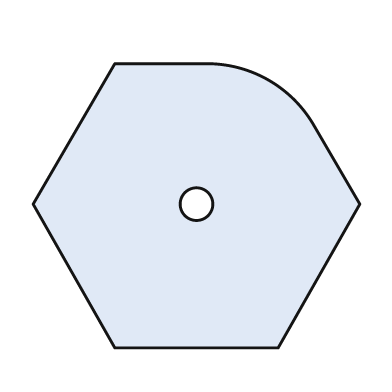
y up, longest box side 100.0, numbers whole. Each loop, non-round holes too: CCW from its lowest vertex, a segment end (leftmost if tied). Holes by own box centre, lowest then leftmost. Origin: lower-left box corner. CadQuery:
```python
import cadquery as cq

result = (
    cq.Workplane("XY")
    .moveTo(25.0, 0.0)
    .lineTo(75.0, 0.0)
    .lineTo(100.0, 44.0)
    .lineTo(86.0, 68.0)
    .threePointArc((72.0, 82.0), (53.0, 87.0))
    .lineTo(25.0, 87.0)
    .lineTo(0.0, 44.0)
    .close()
    .moveTo(50.0, 44.0)
    .circle(5.0)
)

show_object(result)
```